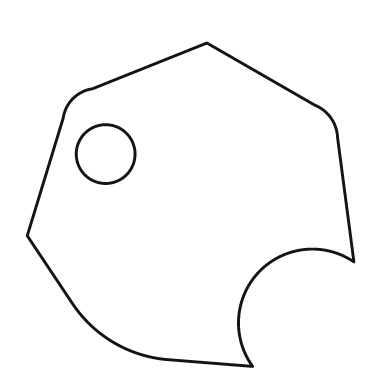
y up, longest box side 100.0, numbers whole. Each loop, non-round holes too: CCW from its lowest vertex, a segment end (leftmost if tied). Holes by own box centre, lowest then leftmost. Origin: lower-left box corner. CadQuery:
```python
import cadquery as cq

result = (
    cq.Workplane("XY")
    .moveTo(69.0, 0.0)
    .threePointArc((71.0, 29.0), (100.0, 32.0))
    .lineTo(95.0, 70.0)
    .threePointArc((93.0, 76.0), (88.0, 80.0))
    .lineTo(55.0, 99.0)
    .lineTo(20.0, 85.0)
    .threePointArc((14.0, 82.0), (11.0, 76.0))
    .lineTo(0.0, 40.0)
    .lineTo(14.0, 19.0)
    .threePointArc((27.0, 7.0), (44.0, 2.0))
    .close()
    .moveTo(24.0, 65.0)
    .circle(9.0)
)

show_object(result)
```